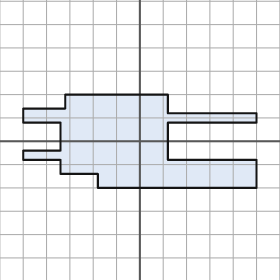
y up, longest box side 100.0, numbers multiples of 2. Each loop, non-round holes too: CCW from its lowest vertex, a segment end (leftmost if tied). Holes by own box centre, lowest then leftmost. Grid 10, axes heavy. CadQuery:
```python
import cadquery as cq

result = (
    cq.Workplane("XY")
    .moveTo(-18.0, -20.0)
    .lineTo(50.0, -20.0)
    .lineTo(50.0, -8.0)
    .lineTo(12.0, -8.0)
    .lineTo(12.0, 8.0)
    .lineTo(50.0, 8.0)
    .lineTo(50.0, 12.0)
    .lineTo(12.0, 12.0)
    .lineTo(12.0, 20.0)
    .lineTo(-32.0, 20.0)
    .lineTo(-32.0, 14.0)
    .lineTo(-50.0, 14.0)
    .lineTo(-50.0, 8.0)
    .lineTo(-34.0, 8.0)
    .lineTo(-34.0, -4.0)
    .lineTo(-50.0, -4.0)
    .lineTo(-50.0, -8.0)
    .lineTo(-34.0, -8.0)
    .lineTo(-34.0, -14.0)
    .lineTo(-18.0, -14.0)
    .close()
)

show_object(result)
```